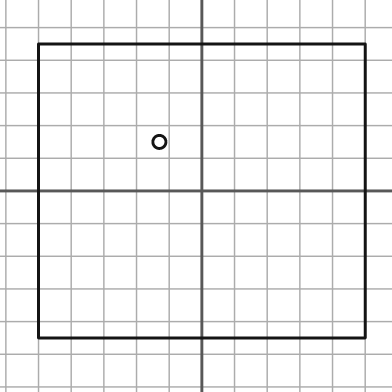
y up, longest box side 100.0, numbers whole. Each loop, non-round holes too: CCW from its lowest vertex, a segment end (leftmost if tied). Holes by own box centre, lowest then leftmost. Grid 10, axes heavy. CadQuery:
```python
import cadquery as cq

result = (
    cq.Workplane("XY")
    .moveTo(-50.0, -45.0)
    .lineTo(50.0, -45.0)
    .lineTo(50.0, 45.0)
    .lineTo(-50.0, 45.0)
    .close()
    .moveTo(-13.0, 15.0)
    .circle(2.0)
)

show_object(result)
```